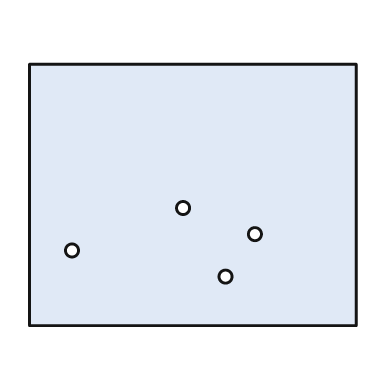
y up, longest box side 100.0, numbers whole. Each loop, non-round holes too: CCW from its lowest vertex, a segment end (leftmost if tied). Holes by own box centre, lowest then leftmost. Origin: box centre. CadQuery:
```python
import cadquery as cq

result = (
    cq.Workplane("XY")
    .moveTo(-50.0, -40.0)
    .lineTo(50.0, -40.0)
    .lineTo(50.0, 40.0)
    .lineTo(-50.0, 40.0)
    .close()
    .moveTo(10.0, -25.0)
    .circle(2.0)
    .moveTo(-37.0, -17.0)
    .circle(2.0)
    .moveTo(19.0, -12.0)
    .circle(2.0)
    .moveTo(-3.0, -4.0)
    .circle(2.0)
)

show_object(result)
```